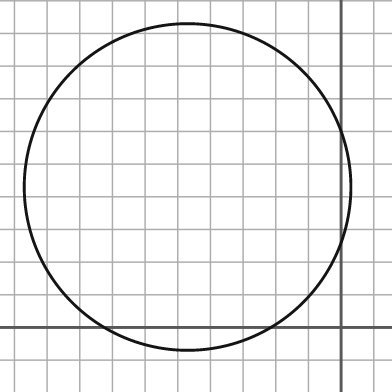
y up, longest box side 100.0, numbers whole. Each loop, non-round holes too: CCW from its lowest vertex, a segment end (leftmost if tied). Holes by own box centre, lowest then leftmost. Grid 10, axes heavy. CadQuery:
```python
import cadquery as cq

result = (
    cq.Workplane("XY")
    .moveTo(-47.0, 43.0)
    .circle(50.0)
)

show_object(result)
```